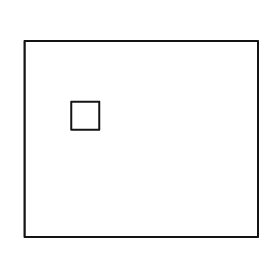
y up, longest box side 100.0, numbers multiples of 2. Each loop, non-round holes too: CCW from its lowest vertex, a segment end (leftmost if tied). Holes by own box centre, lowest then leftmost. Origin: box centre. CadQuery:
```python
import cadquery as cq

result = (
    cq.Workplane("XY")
    .moveTo(-50.0, -42.0)
    .lineTo(50.0, -42.0)
    .lineTo(50.0, 42.0)
    .lineTo(-50.0, 42.0)
    .close()
    .moveTo(-30.0, 4.0)
    .lineTo(-18.0, 4.0)
    .lineTo(-18.0, 16.0)
    .lineTo(-30.0, 16.0)
    .close()
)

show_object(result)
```